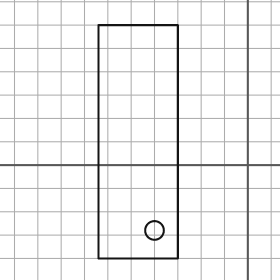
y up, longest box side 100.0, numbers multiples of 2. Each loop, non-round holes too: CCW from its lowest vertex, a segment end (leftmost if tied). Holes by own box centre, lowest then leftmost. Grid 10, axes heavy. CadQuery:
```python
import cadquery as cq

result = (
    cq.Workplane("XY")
    .moveTo(-64.0, -40.0)
    .lineTo(-30.0, -40.0)
    .lineTo(-30.0, 60.0)
    .lineTo(-64.0, 60.0)
    .close()
    .moveTo(-40.0, -28.0)
    .circle(4.0)
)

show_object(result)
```